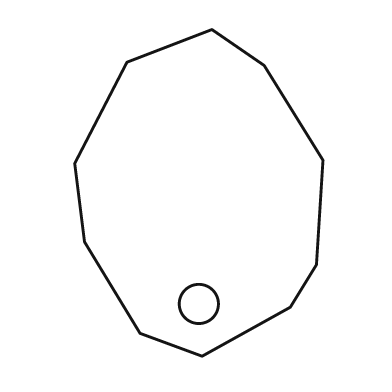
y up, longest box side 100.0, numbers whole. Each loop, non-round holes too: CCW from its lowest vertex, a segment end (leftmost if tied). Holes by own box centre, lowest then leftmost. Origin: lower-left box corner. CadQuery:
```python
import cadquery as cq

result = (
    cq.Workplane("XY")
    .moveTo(39.0, 0.0)
    .lineTo(66.0, 15.0)
    .lineTo(74.0, 28.0)
    .lineTo(76.0, 60.0)
    .lineTo(58.0, 89.0)
    .lineTo(42.0, 100.0)
    .lineTo(16.0, 90.0)
    .lineTo(0.0, 59.0)
    .lineTo(3.0, 35.0)
    .lineTo(20.0, 7.0)
    .close()
    .moveTo(38.0, 16.0)
    .circle(6.0)
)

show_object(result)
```